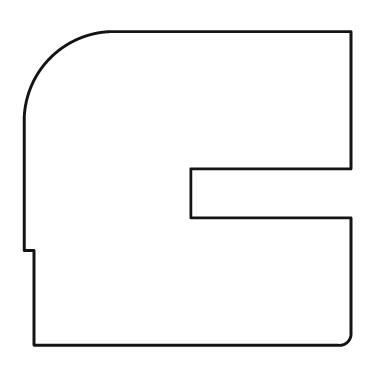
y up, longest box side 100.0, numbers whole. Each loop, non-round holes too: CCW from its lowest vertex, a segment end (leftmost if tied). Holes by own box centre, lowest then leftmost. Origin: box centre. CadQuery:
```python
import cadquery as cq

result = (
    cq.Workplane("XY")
    .moveTo(-47.0, -48.0)
    .lineTo(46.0, -48.0)
    .threePointArc((49.0, -47.0), (50.0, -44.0))
    .lineTo(50.0, -9.0)
    .lineTo(1.0, -9.0)
    .lineTo(1.0, 6.0)
    .lineTo(50.0, 6.0)
    .lineTo(50.0, 48.0)
    .lineTo(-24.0, 48.0)
    .threePointArc((-42.0, 40.0), (-50.0, 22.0))
    .lineTo(-50.0, -19.0)
    .lineTo(-47.0, -19.0)
    .close()
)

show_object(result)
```